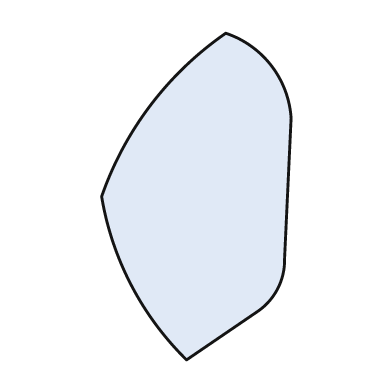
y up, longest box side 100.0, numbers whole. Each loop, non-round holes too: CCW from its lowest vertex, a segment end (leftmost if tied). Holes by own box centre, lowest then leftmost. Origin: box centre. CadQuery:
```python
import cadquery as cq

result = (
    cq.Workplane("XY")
    .moveTo(-3.0, -50.0)
    .lineTo(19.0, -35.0)
    .threePointArc((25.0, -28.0), (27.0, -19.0))
    .lineTo(29.0, 24.0)
    .threePointArc((23.0, 40.0), (9.0, 50.0))
    .threePointArc((-14.0, 28.0), (-29.0, 0.0))
    .threePointArc((-20.0, -27.0), (-3.0, -50.0))
    .close()
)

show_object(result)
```